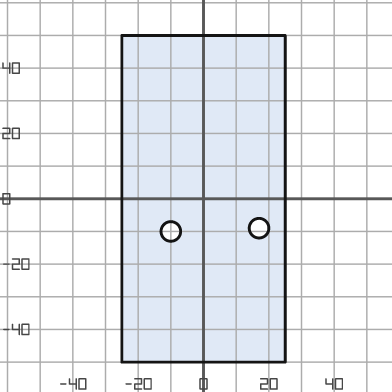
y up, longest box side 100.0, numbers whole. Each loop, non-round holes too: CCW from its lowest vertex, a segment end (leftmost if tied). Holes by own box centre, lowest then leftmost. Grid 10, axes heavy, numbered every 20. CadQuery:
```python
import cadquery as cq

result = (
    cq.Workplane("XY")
    .moveTo(-25.0, -50.0)
    .lineTo(25.0, -50.0)
    .lineTo(25.0, 50.0)
    .lineTo(-25.0, 50.0)
    .close()
    .moveTo(-10.0, -10.0)
    .circle(3.0)
    .moveTo(17.0, -9.0)
    .circle(3.0)
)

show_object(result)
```